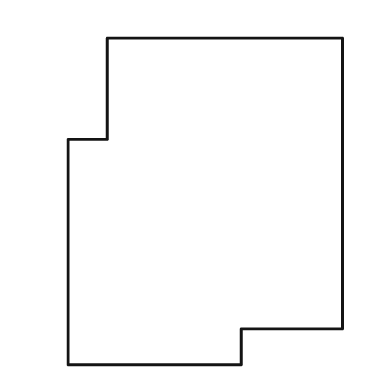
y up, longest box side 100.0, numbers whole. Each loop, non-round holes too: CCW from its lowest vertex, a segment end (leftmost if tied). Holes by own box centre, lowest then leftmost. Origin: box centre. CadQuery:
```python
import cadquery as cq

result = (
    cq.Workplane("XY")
    .moveTo(-42.0, -50.0)
    .lineTo(11.0, -50.0)
    .lineTo(11.0, -39.0)
    .lineTo(42.0, -39.0)
    .lineTo(42.0, 50.0)
    .lineTo(-30.0, 50.0)
    .lineTo(-30.0, 19.0)
    .lineTo(-42.0, 19.0)
    .close()
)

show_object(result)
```